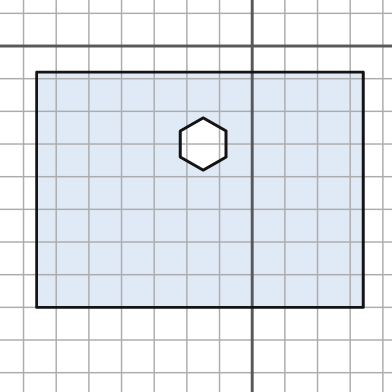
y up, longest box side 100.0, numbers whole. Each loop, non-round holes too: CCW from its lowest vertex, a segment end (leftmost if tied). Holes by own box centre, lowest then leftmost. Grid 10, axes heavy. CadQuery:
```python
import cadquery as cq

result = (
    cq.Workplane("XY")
    .moveTo(-66.0, -80.0)
    .lineTo(34.0, -80.0)
    .lineTo(34.0, -8.0)
    .lineTo(-66.0, -8.0)
    .close()
    .moveTo(-15.0, -38.0)
    .lineTo(-8.0, -34.0)
    .lineTo(-8.0, -26.0)
    .lineTo(-15.0, -22.0)
    .lineTo(-22.0, -26.0)
    .lineTo(-22.0, -34.0)
    .close()
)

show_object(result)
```